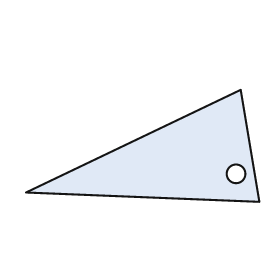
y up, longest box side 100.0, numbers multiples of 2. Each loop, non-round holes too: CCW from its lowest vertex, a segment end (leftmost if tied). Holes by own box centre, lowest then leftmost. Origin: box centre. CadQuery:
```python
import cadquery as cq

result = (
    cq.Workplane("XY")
    .moveTo(50.0, -24.0)
    .lineTo(42.0, 24.0)
    .lineTo(-50.0, -20.0)
    .close()
    .moveTo(40.0, -12.0)
    .circle(4.0)
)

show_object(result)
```